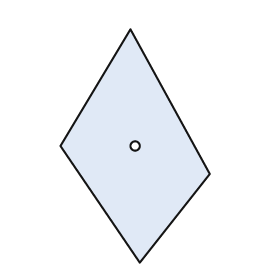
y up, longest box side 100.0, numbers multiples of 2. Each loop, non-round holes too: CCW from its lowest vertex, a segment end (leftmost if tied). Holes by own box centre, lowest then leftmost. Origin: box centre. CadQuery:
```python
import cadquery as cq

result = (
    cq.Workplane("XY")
    .moveTo(2.0, -50.0)
    .lineTo(32.0, -12.0)
    .lineTo(-2.0, 50.0)
    .lineTo(-32.0, 0.0)
    .close()
    .moveTo(0.0, 0.0)
    .circle(2.0)
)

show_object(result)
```